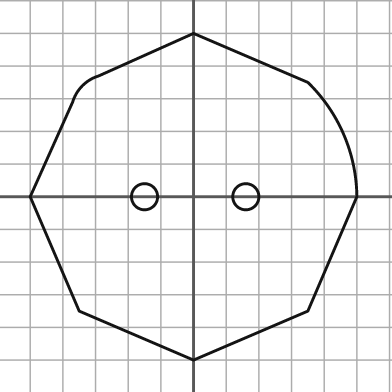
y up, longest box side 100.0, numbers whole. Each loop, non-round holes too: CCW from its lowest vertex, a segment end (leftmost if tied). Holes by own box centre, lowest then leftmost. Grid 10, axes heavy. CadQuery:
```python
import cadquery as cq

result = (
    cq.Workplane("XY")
    .moveTo(0.0, -50.0)
    .lineTo(35.0, -35.0)
    .lineTo(50.0, 0.0)
    .threePointArc((46.0, 19.0), (35.0, 35.0))
    .lineTo(0.0, 50.0)
    .lineTo(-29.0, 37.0)
    .threePointArc((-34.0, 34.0), (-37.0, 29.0))
    .lineTo(-50.0, 0.0)
    .lineTo(-35.0, -35.0)
    .close()
    .moveTo(-15.0, 0.0)
    .circle(4.0)
    .moveTo(16.0, 0.0)
    .circle(4.0)
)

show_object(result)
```